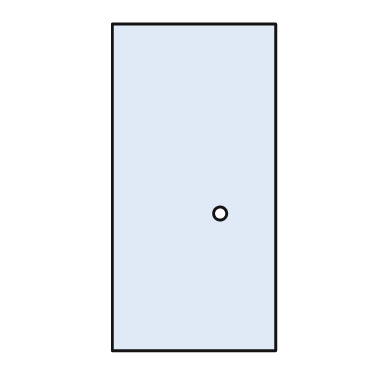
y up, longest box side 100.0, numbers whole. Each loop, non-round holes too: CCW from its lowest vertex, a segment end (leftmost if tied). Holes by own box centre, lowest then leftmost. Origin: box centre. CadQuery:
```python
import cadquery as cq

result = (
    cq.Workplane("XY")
    .moveTo(-25.0, -50.0)
    .lineTo(25.0, -50.0)
    .lineTo(25.0, 50.0)
    .lineTo(-25.0, 50.0)
    .close()
    .moveTo(8.0, -8.0)
    .circle(2.0)
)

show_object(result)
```